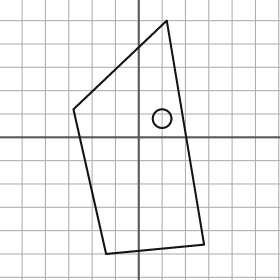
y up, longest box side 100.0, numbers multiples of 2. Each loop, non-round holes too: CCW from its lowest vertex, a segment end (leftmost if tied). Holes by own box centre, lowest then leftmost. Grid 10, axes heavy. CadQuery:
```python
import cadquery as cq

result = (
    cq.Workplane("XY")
    .moveTo(-14.0, -50.0)
    .lineTo(28.0, -46.0)
    .lineTo(12.0, 50.0)
    .lineTo(-28.0, 12.0)
    .close()
    .moveTo(10.0, 8.0)
    .circle(4.0)
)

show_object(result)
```